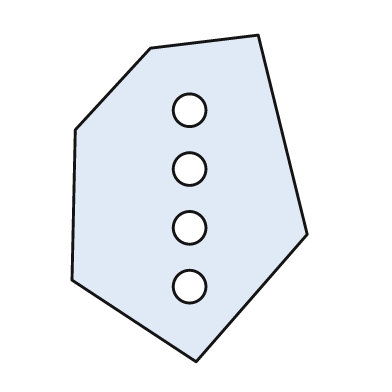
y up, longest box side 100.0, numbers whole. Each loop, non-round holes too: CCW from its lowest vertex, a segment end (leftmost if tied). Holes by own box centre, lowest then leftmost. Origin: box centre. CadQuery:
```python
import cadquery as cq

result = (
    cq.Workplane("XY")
    .moveTo(2.0, -50.0)
    .lineTo(36.0, -11.0)
    .lineTo(21.0, 50.0)
    .lineTo(-12.0, 46.0)
    .lineTo(-35.0, 21.0)
    .lineTo(-36.0, -25.0)
    .close()
    .moveTo(0.0, -27.0)
    .circle(5.0)
    .moveTo(0.0, -9.0)
    .circle(5.0)
    .moveTo(0.0, 9.0)
    .circle(5.0)
    .moveTo(0.0, 27.0)
    .circle(5.0)
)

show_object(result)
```